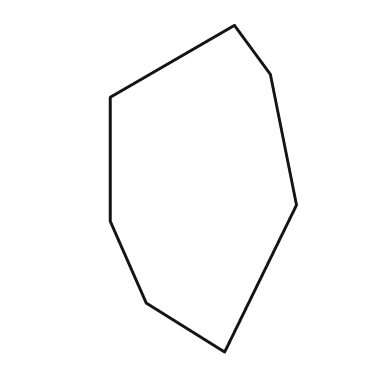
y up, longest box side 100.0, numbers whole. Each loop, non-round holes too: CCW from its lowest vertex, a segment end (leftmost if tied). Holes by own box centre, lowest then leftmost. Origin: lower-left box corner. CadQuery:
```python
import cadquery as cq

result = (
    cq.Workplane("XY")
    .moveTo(35.0, 0.0)
    .lineTo(57.0, 45.0)
    .lineTo(49.0, 85.0)
    .lineTo(38.0, 100.0)
    .lineTo(0.0, 78.0)
    .lineTo(0.0, 40.0)
    .lineTo(11.0, 15.0)
    .close()
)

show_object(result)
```